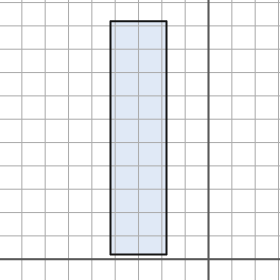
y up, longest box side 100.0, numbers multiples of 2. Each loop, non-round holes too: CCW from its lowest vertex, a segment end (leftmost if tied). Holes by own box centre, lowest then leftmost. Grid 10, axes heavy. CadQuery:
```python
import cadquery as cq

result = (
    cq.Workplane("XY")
    .moveTo(-42.0, 2.0)
    .lineTo(-18.0, 2.0)
    .lineTo(-18.0, 102.0)
    .lineTo(-42.0, 102.0)
    .close()
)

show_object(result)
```